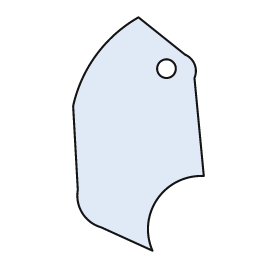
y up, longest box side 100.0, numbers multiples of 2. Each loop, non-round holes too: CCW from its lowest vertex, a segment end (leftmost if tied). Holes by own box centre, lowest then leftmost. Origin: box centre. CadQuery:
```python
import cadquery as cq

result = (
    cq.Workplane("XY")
    .moveTo(6.0, -50.0)
    .threePointArc((8.0, -28.0), (28.0, -18.0))
    .lineTo(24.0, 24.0)
    .threePointArc((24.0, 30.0), (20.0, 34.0))
    .lineTo(0.0, 50.0)
    .threePointArc((-18.0, 34.0), (-28.0, 12.0))
    .lineTo(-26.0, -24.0)
    .threePointArc((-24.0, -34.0), (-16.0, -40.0))
    .close()
    .moveTo(12.0, 28.0)
    .circle(4.0)
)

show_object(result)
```